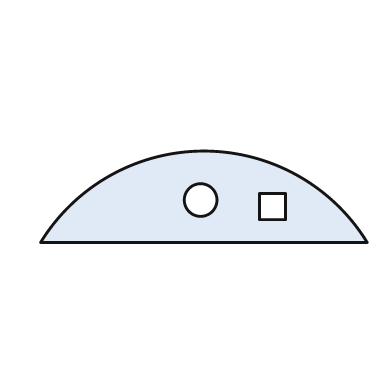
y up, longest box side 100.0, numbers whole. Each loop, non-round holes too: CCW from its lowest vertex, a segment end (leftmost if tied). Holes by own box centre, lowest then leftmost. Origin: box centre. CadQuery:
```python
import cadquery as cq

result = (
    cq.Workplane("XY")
    .moveTo(-50.0, -14.0)
    .lineTo(50.0, -14.0)
    .threePointArc((0.0, 14.0), (-50.0, -14.0))
    .close()
    .moveTo(17.0, -7.0)
    .lineTo(25.0, -7.0)
    .lineTo(25.0, 1.0)
    .lineTo(17.0, 1.0)
    .close()
    .moveTo(-1.0, -1.0)
    .circle(5.0)
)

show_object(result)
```